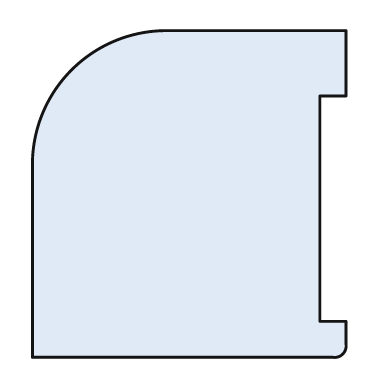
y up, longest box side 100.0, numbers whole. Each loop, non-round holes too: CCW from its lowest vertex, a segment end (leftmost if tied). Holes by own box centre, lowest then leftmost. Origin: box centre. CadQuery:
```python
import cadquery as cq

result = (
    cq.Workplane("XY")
    .moveTo(-48.0, -50.0)
    .lineTo(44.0, -50.0)
    .threePointArc((47.0, -49.0), (48.0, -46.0))
    .lineTo(48.0, -39.0)
    .lineTo(40.0, -39.0)
    .lineTo(40.0, 30.0)
    .lineTo(48.0, 30.0)
    .lineTo(48.0, 50.0)
    .lineTo(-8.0, 50.0)
    .threePointArc((-36.0, 38.0), (-48.0, 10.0))
    .close()
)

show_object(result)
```